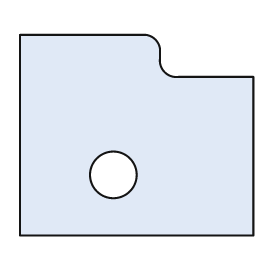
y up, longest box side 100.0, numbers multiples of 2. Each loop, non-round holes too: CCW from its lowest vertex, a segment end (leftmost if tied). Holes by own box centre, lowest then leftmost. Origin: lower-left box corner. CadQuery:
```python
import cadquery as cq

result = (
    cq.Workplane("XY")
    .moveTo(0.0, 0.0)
    .lineTo(100.0, 0.0)
    .lineTo(100.0, 68.0)
    .lineTo(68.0, 68.0)
    .threePointArc((62.0, 70.0), (60.0, 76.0))
    .lineTo(60.0, 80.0)
    .threePointArc((58.0, 84.0), (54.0, 86.0))
    .lineTo(0.0, 86.0)
    .close()
    .moveTo(40.0, 26.0)
    .circle(10.0)
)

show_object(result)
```